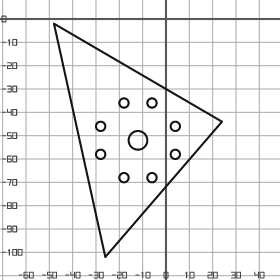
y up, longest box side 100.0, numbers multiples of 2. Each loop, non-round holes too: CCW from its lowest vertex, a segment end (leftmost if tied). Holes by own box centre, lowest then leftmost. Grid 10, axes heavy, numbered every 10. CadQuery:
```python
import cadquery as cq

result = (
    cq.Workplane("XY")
    .moveTo(-26.0, -102.0)
    .lineTo(24.0, -44.0)
    .lineTo(-48.0, -2.0)
    .close()
    .moveTo(-18.0, -68.0)
    .circle(2.0)
    .moveTo(-6.0, -68.0)
    .circle(2.0)
    .moveTo(-28.0, -58.0)
    .circle(2.0)
    .moveTo(4.0, -58.0)
    .circle(2.0)
    .moveTo(-12.0, -52.0)
    .circle(4.0)
    .moveTo(-28.0, -46.0)
    .circle(2.0)
    .moveTo(4.0, -46.0)
    .circle(2.0)
    .moveTo(-18.0, -36.0)
    .circle(2.0)
    .moveTo(-6.0, -36.0)
    .circle(2.0)
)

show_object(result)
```